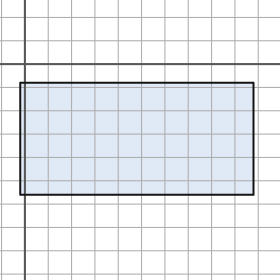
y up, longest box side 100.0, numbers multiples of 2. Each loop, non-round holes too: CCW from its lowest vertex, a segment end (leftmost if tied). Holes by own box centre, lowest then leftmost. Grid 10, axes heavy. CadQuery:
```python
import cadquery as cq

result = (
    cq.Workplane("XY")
    .moveTo(-2.0, -56.0)
    .lineTo(98.0, -56.0)
    .lineTo(98.0, -8.0)
    .lineTo(-2.0, -8.0)
    .close()
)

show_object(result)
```